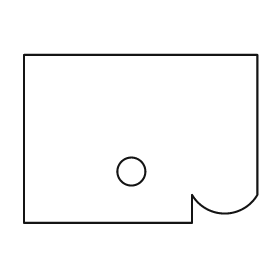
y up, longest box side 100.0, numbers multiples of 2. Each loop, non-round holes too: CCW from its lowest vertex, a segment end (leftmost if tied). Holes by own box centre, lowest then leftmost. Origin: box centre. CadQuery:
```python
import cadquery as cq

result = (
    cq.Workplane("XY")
    .moveTo(-50.0, -36.0)
    .lineTo(22.0, -36.0)
    .lineTo(22.0, -24.0)
    .threePointArc((36.0, -32.0), (50.0, -24.0))
    .lineTo(50.0, 36.0)
    .lineTo(-50.0, 36.0)
    .close()
    .moveTo(-4.0, -14.0)
    .circle(6.0)
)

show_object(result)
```